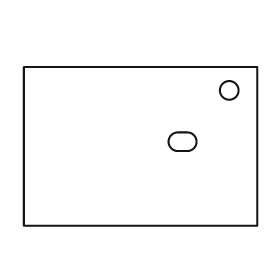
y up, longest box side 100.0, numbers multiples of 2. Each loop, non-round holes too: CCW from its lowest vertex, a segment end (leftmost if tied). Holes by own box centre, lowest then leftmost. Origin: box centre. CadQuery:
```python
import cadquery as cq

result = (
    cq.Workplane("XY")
    .moveTo(-50.0, -34.0)
    .lineTo(50.0, -34.0)
    .lineTo(50.0, 34.0)
    .lineTo(-50.0, 34.0)
    .close()
    .moveTo(16.0, -2.0)
    .lineTo(20.0, -2.0)
    .threePointArc((24.0, 2.0), (20.0, 6.0))
    .lineTo(16.0, 6.0)
    .threePointArc((12.0, 2.0), (16.0, -2.0))
    .close()
    .moveTo(38.0, 24.0)
    .circle(4.0)
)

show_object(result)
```